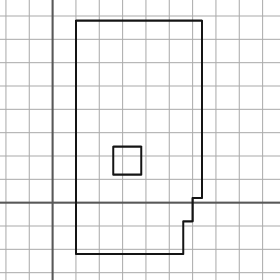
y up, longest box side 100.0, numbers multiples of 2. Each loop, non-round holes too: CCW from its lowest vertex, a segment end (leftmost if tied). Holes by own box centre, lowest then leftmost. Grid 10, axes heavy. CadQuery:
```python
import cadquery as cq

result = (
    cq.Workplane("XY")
    .moveTo(10.0, -22.0)
    .lineTo(56.0, -22.0)
    .lineTo(56.0, -8.0)
    .lineTo(60.0, -8.0)
    .lineTo(60.0, 2.0)
    .lineTo(64.0, 2.0)
    .lineTo(64.0, 78.0)
    .lineTo(10.0, 78.0)
    .close()
    .moveTo(26.0, 12.0)
    .lineTo(38.0, 12.0)
    .lineTo(38.0, 24.0)
    .lineTo(26.0, 24.0)
    .close()
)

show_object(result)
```